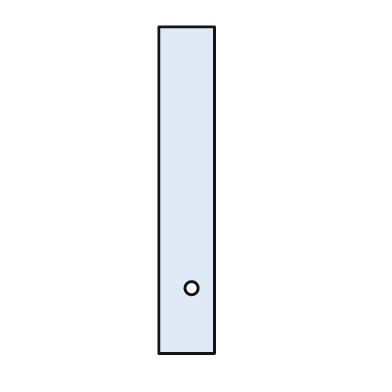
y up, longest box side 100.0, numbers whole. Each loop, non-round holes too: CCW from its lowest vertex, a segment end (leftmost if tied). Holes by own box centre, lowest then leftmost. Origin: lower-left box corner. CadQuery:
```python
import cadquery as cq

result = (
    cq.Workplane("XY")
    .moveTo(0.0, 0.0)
    .lineTo(17.0, 0.0)
    .lineTo(17.0, 100.0)
    .lineTo(0.0, 100.0)
    .close()
    .moveTo(10.0, 20.0)
    .circle(2.0)
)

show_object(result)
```